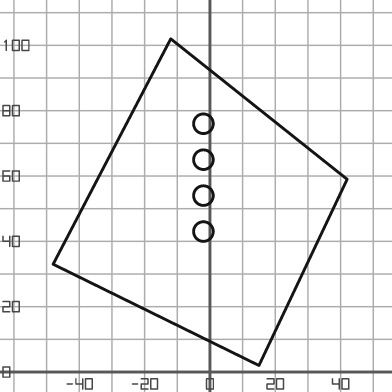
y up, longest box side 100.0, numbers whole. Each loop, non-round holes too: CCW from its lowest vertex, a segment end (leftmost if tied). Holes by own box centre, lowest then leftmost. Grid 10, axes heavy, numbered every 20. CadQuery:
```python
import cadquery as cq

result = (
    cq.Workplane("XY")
    .moveTo(15.0, 2.0)
    .lineTo(42.0, 59.0)
    .lineTo(-12.0, 102.0)
    .lineTo(-48.0, 33.0)
    .close()
    .moveTo(-2.0, 43.0)
    .circle(3.0)
    .moveTo(-2.0, 54.0)
    .circle(3.0)
    .moveTo(-2.0, 65.0)
    .circle(3.0)
    .moveTo(-2.0, 76.0)
    .circle(3.0)
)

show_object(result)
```